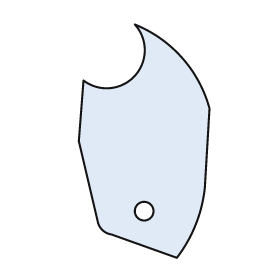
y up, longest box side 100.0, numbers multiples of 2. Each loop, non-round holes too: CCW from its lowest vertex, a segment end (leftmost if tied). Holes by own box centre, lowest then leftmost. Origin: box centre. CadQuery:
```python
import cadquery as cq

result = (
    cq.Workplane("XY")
    .moveTo(14.0, -50.0)
    .threePointArc((22.0, -36.0), (26.0, -20.0))
    .lineTo(28.0, 14.0)
    .threePointArc((16.0, 36.0), (-4.0, 50.0))
    .threePointArc((-4.0, 28.0), (-26.0, 26.0))
    .lineTo(-28.0, 0.0)
    .lineTo(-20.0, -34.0)
    .threePointArc((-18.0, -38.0), (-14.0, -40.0))
    .close()
    .moveTo(0.0, -30.0)
    .circle(4.0)
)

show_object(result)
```